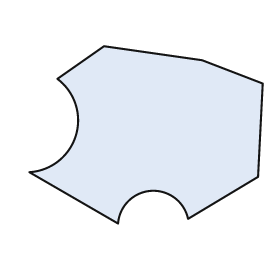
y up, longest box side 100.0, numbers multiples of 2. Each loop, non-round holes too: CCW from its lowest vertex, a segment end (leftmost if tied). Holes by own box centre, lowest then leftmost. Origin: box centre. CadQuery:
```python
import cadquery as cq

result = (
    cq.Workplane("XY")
    .moveTo(-12.0, -38.0)
    .threePointArc((2.0, -24.0), (18.0, -36.0))
    .lineTo(48.0, -18.0)
    .lineTo(50.0, 22.0)
    .lineTo(24.0, 32.0)
    .lineTo(-18.0, 38.0)
    .lineTo(-38.0, 24.0)
    .threePointArc((-30.0, 0.0), (-50.0, -16.0))
    .close()
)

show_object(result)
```